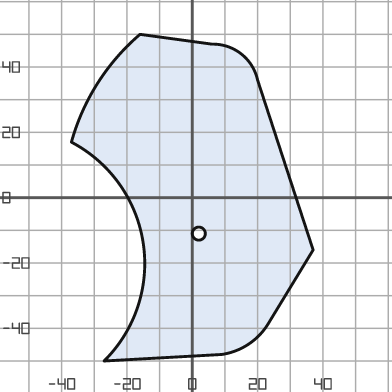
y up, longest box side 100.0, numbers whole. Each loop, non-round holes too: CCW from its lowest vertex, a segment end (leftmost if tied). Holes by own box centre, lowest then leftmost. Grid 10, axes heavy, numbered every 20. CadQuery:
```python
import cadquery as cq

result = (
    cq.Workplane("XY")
    .moveTo(-27.0, -50.0)
    .lineTo(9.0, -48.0)
    .threePointArc((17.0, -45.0), (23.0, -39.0))
    .lineTo(37.0, -16.0)
    .lineTo(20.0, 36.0)
    .threePointArc((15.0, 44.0), (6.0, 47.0))
    .lineTo(-16.0, 50.0)
    .threePointArc((-29.0, 35.0), (-37.0, 17.0))
    .threePointArc((-15.0, -14.0), (-27.0, -50.0))
    .close()
    .moveTo(2.0, -11.0)
    .circle(2.0)
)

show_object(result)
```